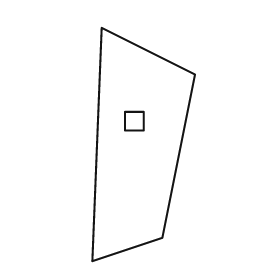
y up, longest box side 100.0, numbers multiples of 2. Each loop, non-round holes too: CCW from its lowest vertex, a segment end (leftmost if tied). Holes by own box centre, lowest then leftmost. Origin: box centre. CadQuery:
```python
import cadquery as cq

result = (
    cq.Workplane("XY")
    .moveTo(-22.0, -50.0)
    .lineTo(8.0, -40.0)
    .lineTo(22.0, 30.0)
    .lineTo(-18.0, 50.0)
    .close()
    .moveTo(-8.0, 6.0)
    .lineTo(0.0, 6.0)
    .lineTo(0.0, 14.0)
    .lineTo(-8.0, 14.0)
    .close()
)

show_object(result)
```